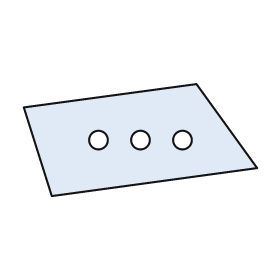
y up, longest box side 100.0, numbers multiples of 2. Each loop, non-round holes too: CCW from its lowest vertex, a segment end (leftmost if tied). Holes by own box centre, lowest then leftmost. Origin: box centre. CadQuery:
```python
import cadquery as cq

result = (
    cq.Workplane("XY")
    .moveTo(-38.0, -24.0)
    .lineTo(50.0, -12.0)
    .lineTo(24.0, 24.0)
    .lineTo(-50.0, 14.0)
    .close()
    .moveTo(-18.0, 0.0)
    .circle(4.0)
    .moveTo(0.0, 0.0)
    .circle(4.0)
    .moveTo(18.0, 0.0)
    .circle(4.0)
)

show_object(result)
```